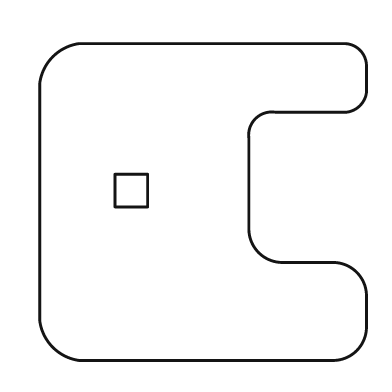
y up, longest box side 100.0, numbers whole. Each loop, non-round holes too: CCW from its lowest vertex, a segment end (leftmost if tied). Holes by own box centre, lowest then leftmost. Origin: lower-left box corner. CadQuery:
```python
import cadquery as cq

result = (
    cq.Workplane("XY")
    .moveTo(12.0, 0.0)
    .lineTo(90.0, 0.0)
    .threePointArc((97.0, 3.0), (100.0, 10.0))
    .lineTo(100.0, 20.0)
    .threePointArc((97.0, 27.0), (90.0, 30.0))
    .lineTo(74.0, 30.0)
    .threePointArc((67.0, 33.0), (64.0, 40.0))
    .lineTo(64.0, 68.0)
    .threePointArc((66.0, 74.0), (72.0, 76.0))
    .lineTo(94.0, 76.0)
    .threePointArc((98.0, 78.0), (100.0, 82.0))
    .lineTo(100.0, 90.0)
    .threePointArc((98.0, 95.0), (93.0, 97.0))
    .lineTo(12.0, 97.0)
    .threePointArc((4.0, 93.0), (0.0, 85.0))
    .lineTo(0.0, 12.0)
    .threePointArc((4.0, 4.0), (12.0, 0.0))
    .close()
    .moveTo(23.0, 47.0)
    .lineTo(33.0, 47.0)
    .lineTo(33.0, 57.0)
    .lineTo(23.0, 57.0)
    .close()
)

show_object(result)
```